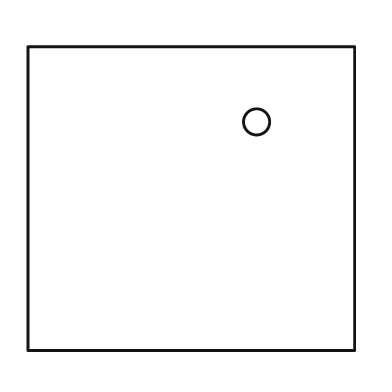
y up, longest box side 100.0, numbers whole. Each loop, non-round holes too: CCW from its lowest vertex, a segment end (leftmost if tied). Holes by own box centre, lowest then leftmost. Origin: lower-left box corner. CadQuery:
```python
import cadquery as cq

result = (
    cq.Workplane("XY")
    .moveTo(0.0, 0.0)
    .lineTo(100.0, 0.0)
    .lineTo(100.0, 93.0)
    .lineTo(0.0, 93.0)
    .close()
    .moveTo(70.0, 70.0)
    .circle(4.0)
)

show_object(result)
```